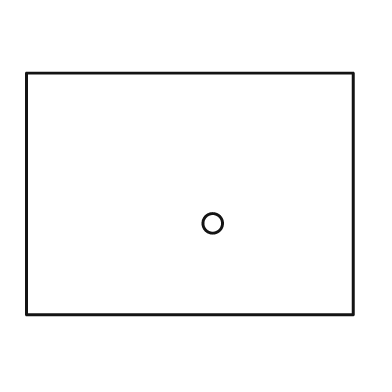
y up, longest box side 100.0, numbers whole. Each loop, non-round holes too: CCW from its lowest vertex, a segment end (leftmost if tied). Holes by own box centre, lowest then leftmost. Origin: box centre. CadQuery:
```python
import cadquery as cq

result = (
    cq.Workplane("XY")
    .moveTo(-50.0, -37.0)
    .lineTo(50.0, -37.0)
    .lineTo(50.0, 37.0)
    .lineTo(-50.0, 37.0)
    .close()
    .moveTo(7.0, -9.0)
    .circle(3.0)
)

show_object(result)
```